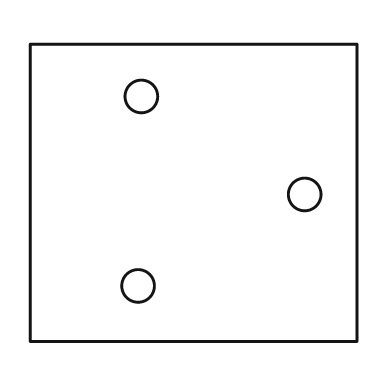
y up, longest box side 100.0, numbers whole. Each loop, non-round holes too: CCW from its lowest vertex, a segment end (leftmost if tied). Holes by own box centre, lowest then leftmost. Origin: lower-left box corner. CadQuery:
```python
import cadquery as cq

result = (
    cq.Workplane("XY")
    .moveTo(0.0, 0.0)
    .lineTo(100.0, 0.0)
    .lineTo(100.0, 91.0)
    .lineTo(0.0, 91.0)
    .close()
    .moveTo(33.0, 17.0)
    .circle(5.0)
    .moveTo(84.0, 45.0)
    .circle(5.0)
    .moveTo(34.0, 75.0)
    .circle(5.0)
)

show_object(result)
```